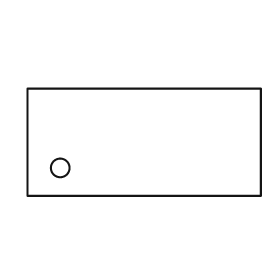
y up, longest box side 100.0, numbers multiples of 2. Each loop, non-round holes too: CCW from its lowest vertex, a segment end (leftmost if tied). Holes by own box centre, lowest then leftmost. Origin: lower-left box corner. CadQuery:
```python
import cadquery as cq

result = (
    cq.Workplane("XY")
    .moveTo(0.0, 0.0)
    .lineTo(100.0, 0.0)
    .lineTo(100.0, 46.0)
    .lineTo(0.0, 46.0)
    .close()
    .moveTo(14.0, 12.0)
    .circle(4.0)
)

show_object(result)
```